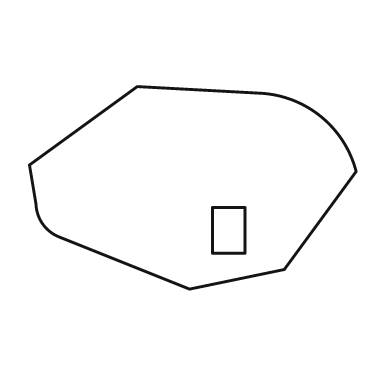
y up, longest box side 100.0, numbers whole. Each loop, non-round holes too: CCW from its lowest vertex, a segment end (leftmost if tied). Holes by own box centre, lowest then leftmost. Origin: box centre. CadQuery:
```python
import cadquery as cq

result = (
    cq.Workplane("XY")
    .moveTo(-1.0, -31.0)
    .lineTo(28.0, -25.0)
    .lineTo(50.0, 5.0)
    .threePointArc((39.0, 22.0), (20.0, 29.0))
    .lineTo(-17.0, 31.0)
    .lineTo(-50.0, 7.0)
    .lineTo(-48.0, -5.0)
    .threePointArc((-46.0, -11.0), (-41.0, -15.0))
    .close()
    .moveTo(6.0, -20.0)
    .lineTo(16.0, -20.0)
    .lineTo(16.0, -6.0)
    .lineTo(6.0, -6.0)
    .close()
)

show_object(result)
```